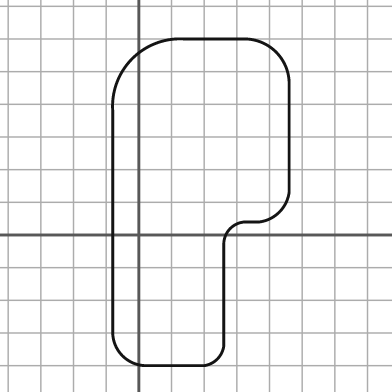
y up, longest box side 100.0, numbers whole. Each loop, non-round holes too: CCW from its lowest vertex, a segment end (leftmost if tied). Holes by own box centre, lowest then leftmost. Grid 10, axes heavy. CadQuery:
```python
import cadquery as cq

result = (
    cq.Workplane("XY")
    .moveTo(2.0, -40.0)
    .lineTo(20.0, -40.0)
    .threePointArc((24.0, -38.0), (26.0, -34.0))
    .lineTo(26.0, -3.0)
    .threePointArc((28.0, 2.0), (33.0, 4.0))
    .lineTo(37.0, 4.0)
    .threePointArc((43.0, 7.0), (46.0, 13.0))
    .lineTo(46.0, 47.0)
    .threePointArc((42.0, 56.0), (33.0, 60.0))
    .lineTo(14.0, 60.0)
    .threePointArc((-2.0, 54.0), (-8.0, 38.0))
    .lineTo(-8.0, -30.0)
    .threePointArc((-5.0, -37.0), (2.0, -40.0))
    .close()
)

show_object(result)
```